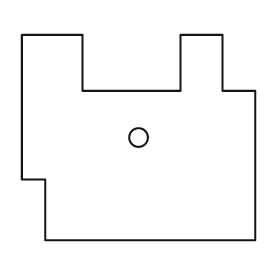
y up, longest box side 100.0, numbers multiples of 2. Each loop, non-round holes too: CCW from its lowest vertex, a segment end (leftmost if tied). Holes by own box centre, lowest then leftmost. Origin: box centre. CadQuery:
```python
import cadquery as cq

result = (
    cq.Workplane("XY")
    .moveTo(-40.0, -44.0)
    .lineTo(50.0, -44.0)
    .lineTo(50.0, 20.0)
    .lineTo(36.0, 20.0)
    .lineTo(36.0, 44.0)
    .lineTo(18.0, 44.0)
    .lineTo(18.0, 20.0)
    .lineTo(-24.0, 20.0)
    .lineTo(-24.0, 44.0)
    .lineTo(-50.0, 44.0)
    .lineTo(-50.0, -18.0)
    .lineTo(-40.0, -18.0)
    .close()
    .moveTo(0.0, 0.0)
    .circle(4.0)
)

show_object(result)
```